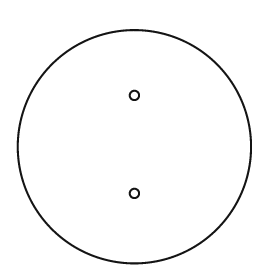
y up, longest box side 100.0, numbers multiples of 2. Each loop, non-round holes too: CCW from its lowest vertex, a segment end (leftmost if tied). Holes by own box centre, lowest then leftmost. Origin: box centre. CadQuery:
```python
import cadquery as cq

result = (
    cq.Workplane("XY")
    .moveTo(0.0, 0.0)
    .circle(50.0)
    .moveTo(0.0, -20.0)
    .circle(2.0)
    .moveTo(0.0, 22.0)
    .circle(2.0)
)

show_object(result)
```